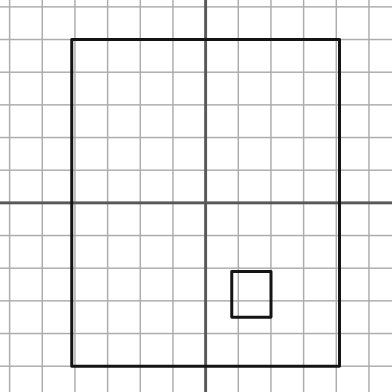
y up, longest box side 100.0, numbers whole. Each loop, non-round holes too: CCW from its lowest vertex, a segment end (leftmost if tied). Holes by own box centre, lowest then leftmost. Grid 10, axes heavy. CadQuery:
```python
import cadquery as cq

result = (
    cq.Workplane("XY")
    .moveTo(-41.0, -50.0)
    .lineTo(41.0, -50.0)
    .lineTo(41.0, 50.0)
    .lineTo(-41.0, 50.0)
    .close()
    .moveTo(8.0, -35.0)
    .lineTo(20.0, -35.0)
    .lineTo(20.0, -21.0)
    .lineTo(8.0, -21.0)
    .close()
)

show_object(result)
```